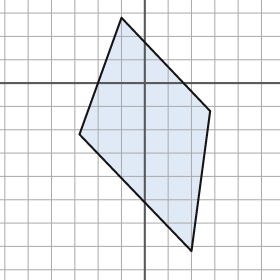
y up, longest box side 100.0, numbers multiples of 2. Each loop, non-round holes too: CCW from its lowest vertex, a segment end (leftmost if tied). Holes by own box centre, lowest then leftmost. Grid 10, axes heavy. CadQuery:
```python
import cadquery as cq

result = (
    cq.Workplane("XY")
    .moveTo(20.0, -72.0)
    .lineTo(28.0, -12.0)
    .lineTo(-10.0, 28.0)
    .lineTo(-28.0, -22.0)
    .close()
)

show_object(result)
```